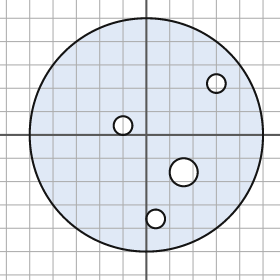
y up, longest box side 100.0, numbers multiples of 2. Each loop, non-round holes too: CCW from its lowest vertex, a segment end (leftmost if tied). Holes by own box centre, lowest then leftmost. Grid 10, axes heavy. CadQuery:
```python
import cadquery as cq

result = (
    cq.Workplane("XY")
    .moveTo(0.0, 0.0)
    .circle(50.0)
    .moveTo(4.0, -36.0)
    .circle(4.0)
    .moveTo(16.0, -16.0)
    .circle(6.0)
    .moveTo(-10.0, 4.0)
    .circle(4.0)
    .moveTo(30.0, 22.0)
    .circle(4.0)
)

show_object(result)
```